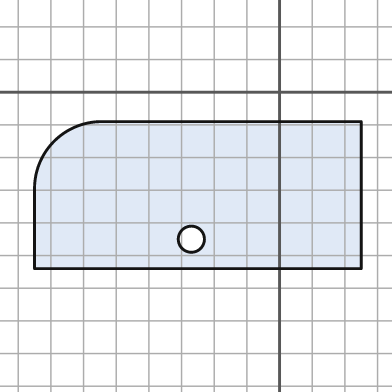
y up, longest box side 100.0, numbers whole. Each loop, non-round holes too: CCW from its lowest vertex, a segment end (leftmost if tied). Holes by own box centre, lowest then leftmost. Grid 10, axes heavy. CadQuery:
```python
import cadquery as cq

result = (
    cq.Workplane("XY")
    .moveTo(-75.0, -54.0)
    .lineTo(25.0, -54.0)
    .lineTo(25.0, -9.0)
    .lineTo(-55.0, -9.0)
    .threePointArc((-69.0, -15.0), (-75.0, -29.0))
    .close()
    .moveTo(-27.0, -45.0)
    .circle(4.0)
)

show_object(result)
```